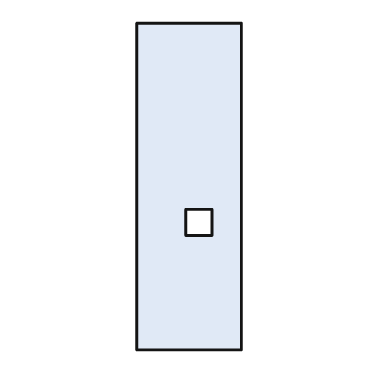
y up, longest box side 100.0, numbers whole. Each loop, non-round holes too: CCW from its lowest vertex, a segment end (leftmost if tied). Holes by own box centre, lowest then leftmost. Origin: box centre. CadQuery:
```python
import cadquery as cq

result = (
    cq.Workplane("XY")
    .moveTo(-16.0, -50.0)
    .lineTo(16.0, -50.0)
    .lineTo(16.0, 50.0)
    .lineTo(-16.0, 50.0)
    .close()
    .moveTo(-1.0, -15.0)
    .lineTo(7.0, -15.0)
    .lineTo(7.0, -7.0)
    .lineTo(-1.0, -7.0)
    .close()
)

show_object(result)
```